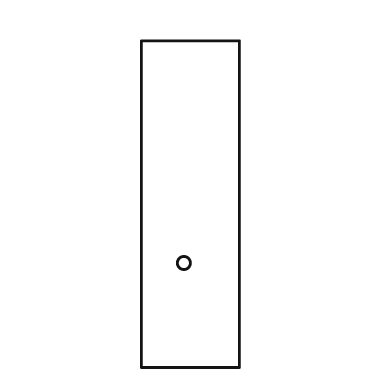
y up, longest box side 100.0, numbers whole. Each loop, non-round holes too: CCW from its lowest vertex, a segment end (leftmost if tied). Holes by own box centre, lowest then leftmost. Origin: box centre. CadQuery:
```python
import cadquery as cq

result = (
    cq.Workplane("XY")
    .moveTo(-15.0, -50.0)
    .lineTo(15.0, -50.0)
    .lineTo(15.0, 50.0)
    .lineTo(-15.0, 50.0)
    .close()
    .moveTo(-2.0, -18.0)
    .circle(2.0)
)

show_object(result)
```